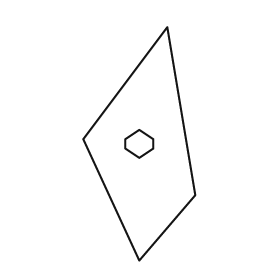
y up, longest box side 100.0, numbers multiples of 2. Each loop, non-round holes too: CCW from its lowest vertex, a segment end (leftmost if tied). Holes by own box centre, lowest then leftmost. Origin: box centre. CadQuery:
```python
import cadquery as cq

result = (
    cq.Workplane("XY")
    .moveTo(0.0, -50.0)
    .lineTo(24.0, -22.0)
    .lineTo(12.0, 50.0)
    .lineTo(-24.0, 2.0)
    .close()
    .moveTo(0.0, -6.0)
    .lineTo(6.0, -2.0)
    .lineTo(6.0, 2.0)
    .lineTo(0.0, 6.0)
    .lineTo(-6.0, 2.0)
    .lineTo(-6.0, -2.0)
    .close()
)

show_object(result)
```